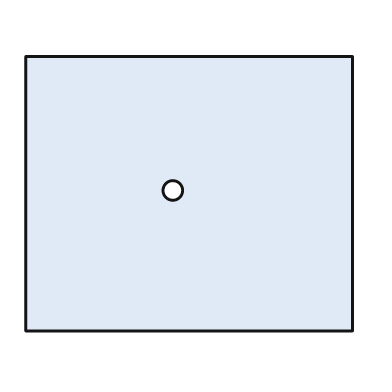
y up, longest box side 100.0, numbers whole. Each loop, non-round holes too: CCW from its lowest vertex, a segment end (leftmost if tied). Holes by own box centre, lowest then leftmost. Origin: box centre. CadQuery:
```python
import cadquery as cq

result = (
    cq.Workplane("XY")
    .moveTo(-50.0, -42.0)
    .lineTo(50.0, -42.0)
    .lineTo(50.0, 42.0)
    .lineTo(-50.0, 42.0)
    .close()
    .moveTo(-5.0, 1.0)
    .circle(3.0)
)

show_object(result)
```